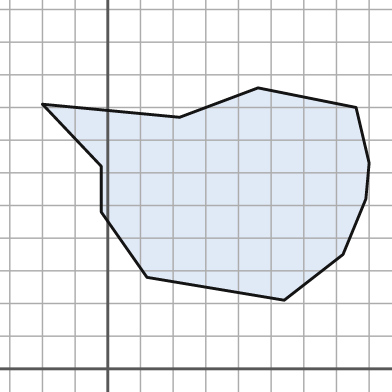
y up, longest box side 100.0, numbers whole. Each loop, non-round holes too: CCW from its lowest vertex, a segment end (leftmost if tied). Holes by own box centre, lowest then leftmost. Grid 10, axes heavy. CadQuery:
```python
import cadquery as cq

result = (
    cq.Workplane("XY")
    .moveTo(54.0, 21.0)
    .lineTo(72.0, 35.0)
    .lineTo(79.0, 52.0)
    .lineTo(80.0, 63.0)
    .lineTo(76.0, 80.0)
    .lineTo(46.0, 86.0)
    .lineTo(22.0, 77.0)
    .lineTo(-20.0, 81.0)
    .lineTo(-2.0, 62.0)
    .lineTo(-2.0, 48.0)
    .lineTo(12.0, 28.0)
    .close()
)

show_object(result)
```